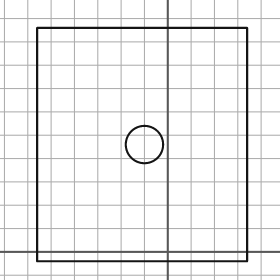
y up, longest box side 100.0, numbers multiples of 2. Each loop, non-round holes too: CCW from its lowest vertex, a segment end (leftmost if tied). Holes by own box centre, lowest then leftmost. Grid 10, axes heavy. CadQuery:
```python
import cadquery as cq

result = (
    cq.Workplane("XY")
    .moveTo(-56.0, -4.0)
    .lineTo(34.0, -4.0)
    .lineTo(34.0, 96.0)
    .lineTo(-56.0, 96.0)
    .close()
    .moveTo(-10.0, 46.0)
    .circle(8.0)
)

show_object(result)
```